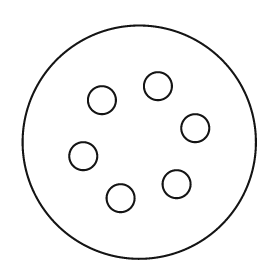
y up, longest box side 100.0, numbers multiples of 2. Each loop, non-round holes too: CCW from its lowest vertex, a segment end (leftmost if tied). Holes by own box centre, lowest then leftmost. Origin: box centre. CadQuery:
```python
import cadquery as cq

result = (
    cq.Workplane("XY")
    .moveTo(0.0, 0.0)
    .circle(50.0)
    .moveTo(-8.0, -24.0)
    .circle(6.0)
    .moveTo(16.0, -18.0)
    .circle(6.0)
    .moveTo(-24.0, -6.0)
    .circle(6.0)
    .moveTo(24.0, 6.0)
    .circle(6.0)
    .moveTo(-16.0, 18.0)
    .circle(6.0)
    .moveTo(8.0, 24.0)
    .circle(6.0)
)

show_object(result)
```